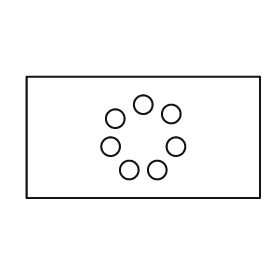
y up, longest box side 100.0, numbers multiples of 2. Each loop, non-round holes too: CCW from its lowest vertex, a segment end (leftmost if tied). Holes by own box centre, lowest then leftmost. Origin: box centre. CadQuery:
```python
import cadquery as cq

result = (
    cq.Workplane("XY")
    .moveTo(-50.0, -26.0)
    .lineTo(50.0, -26.0)
    .lineTo(50.0, 26.0)
    .lineTo(-50.0, 26.0)
    .close()
    .moveTo(-6.0, -14.0)
    .circle(4.0)
    .moveTo(6.0, -14.0)
    .circle(4.0)
    .moveTo(-14.0, -4.0)
    .circle(4.0)
    .moveTo(14.0, -4.0)
    .circle(4.0)
    .moveTo(-12.0, 8.0)
    .circle(4.0)
    .moveTo(12.0, 10.0)
    .circle(4.0)
    .moveTo(0.0, 14.0)
    .circle(4.0)
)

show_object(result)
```